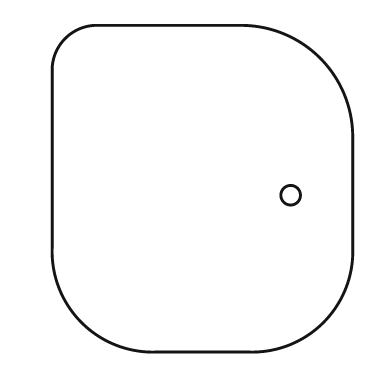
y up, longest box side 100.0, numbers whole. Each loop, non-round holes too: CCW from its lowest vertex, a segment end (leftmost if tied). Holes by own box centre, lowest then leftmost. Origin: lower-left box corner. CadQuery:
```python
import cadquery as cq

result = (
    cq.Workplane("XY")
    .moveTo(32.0, 0.0)
    .lineTo(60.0, 0.0)
    .threePointArc((83.0, 9.0), (92.0, 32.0))
    .lineTo(92.0, 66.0)
    .threePointArc((82.0, 90.0), (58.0, 100.0))
    .lineTo(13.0, 100.0)
    .threePointArc((4.0, 96.0), (0.0, 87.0))
    .lineTo(0.0, 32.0)
    .threePointArc((9.0, 9.0), (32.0, 0.0))
    .close()
    .moveTo(73.0, 48.0)
    .circle(3.0)
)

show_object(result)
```